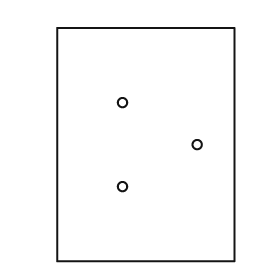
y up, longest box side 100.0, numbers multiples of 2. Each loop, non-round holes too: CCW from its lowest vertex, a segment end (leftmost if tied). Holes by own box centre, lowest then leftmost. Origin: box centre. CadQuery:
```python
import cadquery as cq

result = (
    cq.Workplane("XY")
    .moveTo(-38.0, -50.0)
    .lineTo(38.0, -50.0)
    .lineTo(38.0, 50.0)
    .lineTo(-38.0, 50.0)
    .close()
    .moveTo(-10.0, -18.0)
    .circle(2.0)
    .moveTo(22.0, 0.0)
    .circle(2.0)
    .moveTo(-10.0, 18.0)
    .circle(2.0)
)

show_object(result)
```